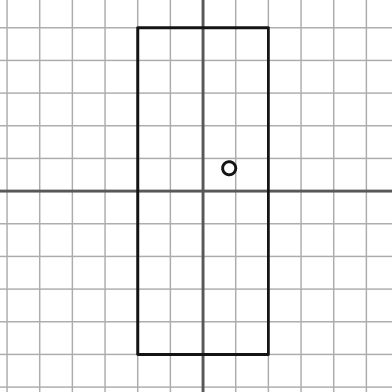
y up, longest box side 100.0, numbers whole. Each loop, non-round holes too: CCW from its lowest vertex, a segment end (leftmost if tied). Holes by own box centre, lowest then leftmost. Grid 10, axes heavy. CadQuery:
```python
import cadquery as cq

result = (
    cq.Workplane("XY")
    .moveTo(-20.0, -50.0)
    .lineTo(20.0, -50.0)
    .lineTo(20.0, 50.0)
    .lineTo(-20.0, 50.0)
    .close()
    .moveTo(8.0, 7.0)
    .circle(2.0)
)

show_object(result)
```